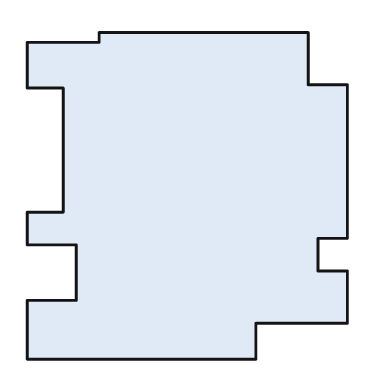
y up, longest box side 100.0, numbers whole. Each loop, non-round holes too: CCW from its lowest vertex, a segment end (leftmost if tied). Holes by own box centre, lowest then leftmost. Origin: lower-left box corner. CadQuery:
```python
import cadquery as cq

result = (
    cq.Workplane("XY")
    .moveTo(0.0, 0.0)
    .lineTo(70.0, 0.0)
    .lineTo(70.0, 11.0)
    .lineTo(98.0, 11.0)
    .lineTo(98.0, 27.0)
    .lineTo(89.0, 27.0)
    .lineTo(89.0, 37.0)
    .lineTo(98.0, 37.0)
    .lineTo(98.0, 84.0)
    .lineTo(86.0, 84.0)
    .lineTo(86.0, 100.0)
    .lineTo(22.0, 100.0)
    .lineTo(22.0, 97.0)
    .lineTo(0.0, 97.0)
    .lineTo(0.0, 83.0)
    .lineTo(11.0, 83.0)
    .lineTo(11.0, 45.0)
    .lineTo(0.0, 45.0)
    .lineTo(0.0, 35.0)
    .lineTo(15.0, 35.0)
    .lineTo(15.0, 18.0)
    .lineTo(0.0, 18.0)
    .close()
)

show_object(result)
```